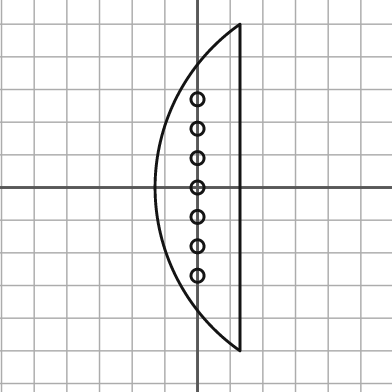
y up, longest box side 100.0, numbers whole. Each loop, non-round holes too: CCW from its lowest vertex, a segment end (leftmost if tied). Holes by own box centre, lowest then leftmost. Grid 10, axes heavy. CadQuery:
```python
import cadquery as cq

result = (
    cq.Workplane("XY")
    .moveTo(13.0, -50.0)
    .lineTo(13.0, 50.0)
    .threePointArc((-13.0, 0.0), (13.0, -50.0))
    .close()
    .moveTo(0.0, -27.0)
    .circle(2.0)
    .moveTo(0.0, -18.0)
    .circle(2.0)
    .moveTo(0.0, -9.0)
    .circle(2.0)
    .moveTo(0.0, 0.0)
    .circle(2.0)
    .moveTo(0.0, 9.0)
    .circle(2.0)
    .moveTo(0.0, 18.0)
    .circle(2.0)
    .moveTo(0.0, 27.0)
    .circle(2.0)
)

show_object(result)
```